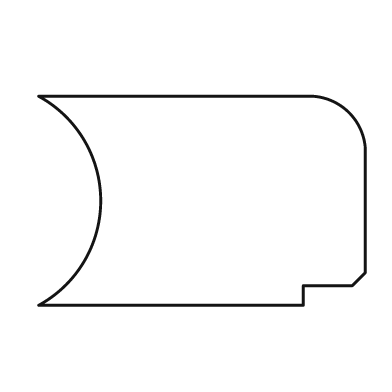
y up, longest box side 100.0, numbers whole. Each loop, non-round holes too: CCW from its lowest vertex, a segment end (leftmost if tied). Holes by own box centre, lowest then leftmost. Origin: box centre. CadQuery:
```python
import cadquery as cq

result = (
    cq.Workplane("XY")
    .moveTo(-50.0, -32.0)
    .lineTo(31.0, -32.0)
    .lineTo(31.0, -26.0)
    .lineTo(46.0, -26.0)
    .lineTo(50.0, -22.0)
    .lineTo(50.0, 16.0)
    .threePointArc((45.0, 27.0), (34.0, 32.0))
    .lineTo(-50.0, 32.0)
    .threePointArc((-31.0, 0.0), (-50.0, -32.0))
    .close()
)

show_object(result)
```